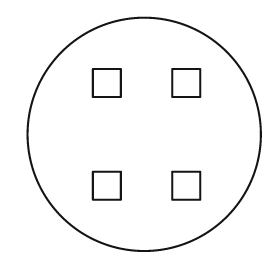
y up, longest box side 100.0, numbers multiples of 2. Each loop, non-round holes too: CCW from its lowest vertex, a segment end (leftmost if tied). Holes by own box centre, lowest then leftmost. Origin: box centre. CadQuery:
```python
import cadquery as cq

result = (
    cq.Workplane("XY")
    .moveTo(0.0, 0.0)
    .circle(50.0)
    .moveTo(-22.0, -28.0)
    .lineTo(-10.0, -28.0)
    .lineTo(-10.0, -16.0)
    .lineTo(-22.0, -16.0)
    .close()
    .moveTo(12.0, -28.0)
    .lineTo(24.0, -28.0)
    .lineTo(24.0, -16.0)
    .lineTo(12.0, -16.0)
    .close()
    .moveTo(-22.0, 16.0)
    .lineTo(-10.0, 16.0)
    .lineTo(-10.0, 28.0)
    .lineTo(-22.0, 28.0)
    .close()
    .moveTo(12.0, 16.0)
    .lineTo(24.0, 16.0)
    .lineTo(24.0, 28.0)
    .lineTo(12.0, 28.0)
    .close()
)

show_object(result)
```